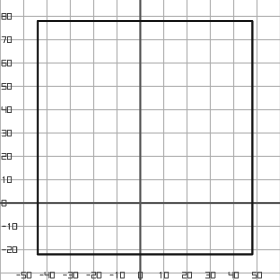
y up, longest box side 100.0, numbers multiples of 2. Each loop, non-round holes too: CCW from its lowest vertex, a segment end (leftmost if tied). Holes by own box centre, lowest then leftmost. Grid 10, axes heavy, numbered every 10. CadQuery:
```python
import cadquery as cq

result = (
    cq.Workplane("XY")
    .moveTo(-44.0, -22.0)
    .lineTo(48.0, -22.0)
    .lineTo(48.0, 78.0)
    .lineTo(-44.0, 78.0)
    .close()
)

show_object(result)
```